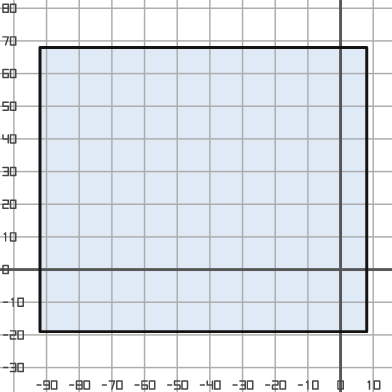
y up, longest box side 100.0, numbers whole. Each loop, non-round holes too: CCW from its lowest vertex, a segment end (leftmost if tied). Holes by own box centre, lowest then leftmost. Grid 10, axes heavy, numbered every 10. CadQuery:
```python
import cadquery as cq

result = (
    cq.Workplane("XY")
    .moveTo(-92.0, -19.0)
    .lineTo(8.0, -19.0)
    .lineTo(8.0, 68.0)
    .lineTo(-92.0, 68.0)
    .close()
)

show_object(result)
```